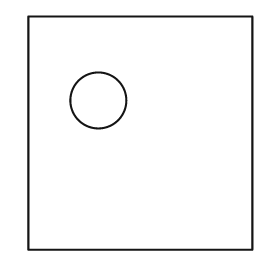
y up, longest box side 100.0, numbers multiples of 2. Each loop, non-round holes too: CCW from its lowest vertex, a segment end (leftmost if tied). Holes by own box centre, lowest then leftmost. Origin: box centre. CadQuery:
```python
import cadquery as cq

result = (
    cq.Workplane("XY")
    .moveTo(-48.0, -50.0)
    .lineTo(48.0, -50.0)
    .lineTo(48.0, 50.0)
    .lineTo(-48.0, 50.0)
    .close()
    .moveTo(-18.0, 14.0)
    .circle(12.0)
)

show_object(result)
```